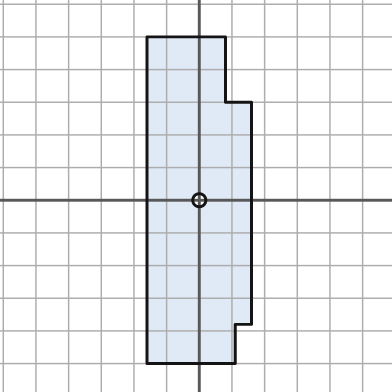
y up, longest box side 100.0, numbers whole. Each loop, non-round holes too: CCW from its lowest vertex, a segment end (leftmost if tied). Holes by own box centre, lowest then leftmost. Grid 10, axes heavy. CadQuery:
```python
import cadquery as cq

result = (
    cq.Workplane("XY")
    .moveTo(-16.0, -50.0)
    .lineTo(11.0, -50.0)
    .lineTo(11.0, -38.0)
    .lineTo(16.0, -38.0)
    .lineTo(16.0, 30.0)
    .lineTo(8.0, 30.0)
    .lineTo(8.0, 50.0)
    .lineTo(-16.0, 50.0)
    .close()
    .moveTo(0.0, 0.0)
    .circle(2.0)
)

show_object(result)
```